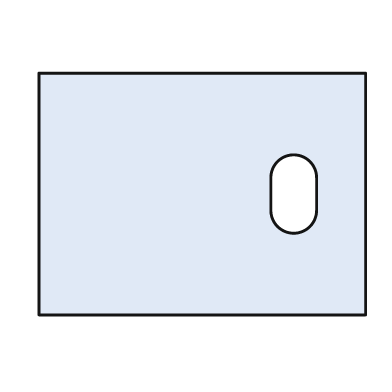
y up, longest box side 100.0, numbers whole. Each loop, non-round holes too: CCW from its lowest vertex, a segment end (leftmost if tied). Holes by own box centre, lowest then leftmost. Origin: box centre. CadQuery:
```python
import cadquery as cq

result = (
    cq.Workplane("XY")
    .moveTo(-50.0, -37.0)
    .lineTo(50.0, -37.0)
    .lineTo(50.0, 37.0)
    .lineTo(-50.0, 37.0)
    .close()
    .moveTo(21.0, -5.0)
    .threePointArc((28.0, -12.0), (35.0, -5.0))
    .lineTo(35.0, 5.0)
    .threePointArc((28.0, 12.0), (21.0, 5.0))
    .close()
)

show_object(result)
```